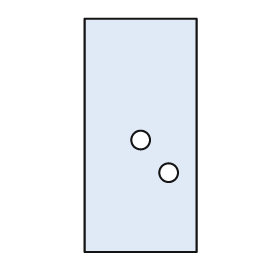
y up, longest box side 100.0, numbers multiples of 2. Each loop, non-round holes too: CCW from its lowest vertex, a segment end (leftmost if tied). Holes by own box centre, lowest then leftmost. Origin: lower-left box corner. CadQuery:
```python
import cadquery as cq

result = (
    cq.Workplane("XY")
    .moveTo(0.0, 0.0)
    .lineTo(48.0, 0.0)
    .lineTo(48.0, 100.0)
    .lineTo(0.0, 100.0)
    .close()
    .moveTo(36.0, 34.0)
    .circle(4.0)
    .moveTo(24.0, 48.0)
    .circle(4.0)
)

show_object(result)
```